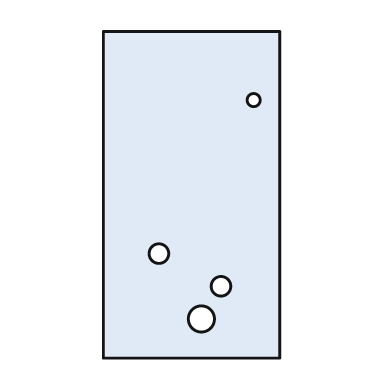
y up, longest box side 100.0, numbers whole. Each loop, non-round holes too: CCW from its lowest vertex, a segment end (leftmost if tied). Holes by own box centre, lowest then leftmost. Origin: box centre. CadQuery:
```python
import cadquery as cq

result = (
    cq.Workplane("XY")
    .moveTo(-27.0, -50.0)
    .lineTo(27.0, -50.0)
    .lineTo(27.0, 50.0)
    .lineTo(-27.0, 50.0)
    .close()
    .moveTo(3.0, -38.0)
    .circle(4.0)
    .moveTo(9.0, -28.0)
    .circle(3.0)
    .moveTo(-10.0, -18.0)
    .circle(3.0)
    .moveTo(19.0, 29.0)
    .circle(2.0)
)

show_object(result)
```